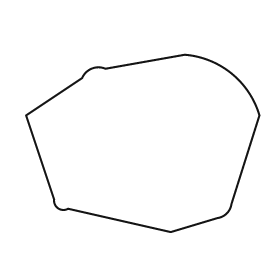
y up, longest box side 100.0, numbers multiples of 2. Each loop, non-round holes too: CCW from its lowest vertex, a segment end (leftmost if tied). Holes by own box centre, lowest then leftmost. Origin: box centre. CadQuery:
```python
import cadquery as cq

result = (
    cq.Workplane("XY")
    .moveTo(12.0, -38.0)
    .lineTo(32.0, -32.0)
    .threePointArc((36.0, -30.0), (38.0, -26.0))
    .lineTo(50.0, 12.0)
    .threePointArc((38.0, 30.0), (18.0, 38.0))
    .lineTo(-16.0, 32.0)
    .threePointArc((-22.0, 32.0), (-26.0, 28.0))
    .lineTo(-50.0, 12.0)
    .lineTo(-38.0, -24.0)
    .threePointArc((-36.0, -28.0), (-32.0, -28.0))
    .close()
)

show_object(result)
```